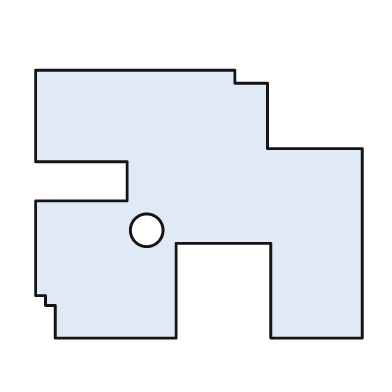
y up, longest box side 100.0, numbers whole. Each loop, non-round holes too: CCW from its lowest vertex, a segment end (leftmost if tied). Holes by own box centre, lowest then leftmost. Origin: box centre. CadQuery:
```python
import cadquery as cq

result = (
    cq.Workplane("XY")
    .moveTo(-44.0, -41.0)
    .lineTo(-7.0, -41.0)
    .lineTo(-7.0, -12.0)
    .lineTo(22.0, -12.0)
    .lineTo(22.0, -41.0)
    .lineTo(50.0, -41.0)
    .lineTo(50.0, 17.0)
    .lineTo(21.0, 17.0)
    .lineTo(21.0, 37.0)
    .lineTo(11.0, 37.0)
    .lineTo(11.0, 41.0)
    .lineTo(-50.0, 41.0)
    .lineTo(-50.0, 13.0)
    .lineTo(-22.0, 13.0)
    .lineTo(-22.0, 1.0)
    .lineTo(-50.0, 1.0)
    .lineTo(-50.0, -28.0)
    .lineTo(-47.0, -28.0)
    .lineTo(-47.0, -31.0)
    .lineTo(-44.0, -31.0)
    .close()
    .moveTo(-16.0, -8.0)
    .circle(5.0)
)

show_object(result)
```